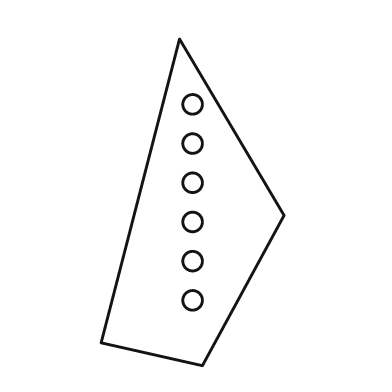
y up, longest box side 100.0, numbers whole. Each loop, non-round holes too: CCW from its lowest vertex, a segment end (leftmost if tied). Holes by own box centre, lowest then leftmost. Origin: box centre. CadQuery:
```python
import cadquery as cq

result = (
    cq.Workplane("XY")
    .moveTo(3.0, -50.0)
    .lineTo(28.0, -4.0)
    .lineTo(-4.0, 50.0)
    .lineTo(-28.0, -43.0)
    .close()
    .moveTo(0.0, -30.0)
    .circle(3.0)
    .moveTo(0.0, -18.0)
    .circle(3.0)
    .moveTo(0.0, -6.0)
    .circle(3.0)
    .moveTo(0.0, 6.0)
    .circle(3.0)
    .moveTo(0.0, 18.0)
    .circle(3.0)
    .moveTo(0.0, 30.0)
    .circle(3.0)
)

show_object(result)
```